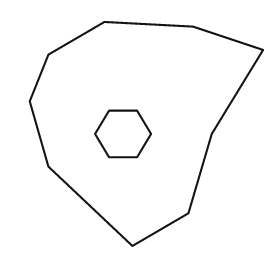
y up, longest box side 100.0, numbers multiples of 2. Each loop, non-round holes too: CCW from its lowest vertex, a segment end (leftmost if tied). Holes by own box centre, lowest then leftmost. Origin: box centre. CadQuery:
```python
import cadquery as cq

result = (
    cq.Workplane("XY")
    .moveTo(-6.0, -48.0)
    .lineTo(18.0, -34.0)
    .lineTo(28.0, 0.0)
    .lineTo(50.0, 36.0)
    .lineTo(20.0, 46.0)
    .lineTo(-18.0, 48.0)
    .lineTo(-42.0, 34.0)
    .lineTo(-50.0, 14.0)
    .lineTo(-42.0, -14.0)
    .close()
    .moveTo(-16.0, -10.0)
    .lineTo(-4.0, -10.0)
    .lineTo(2.0, 0.0)
    .lineTo(-4.0, 10.0)
    .lineTo(-16.0, 10.0)
    .lineTo(-22.0, 0.0)
    .close()
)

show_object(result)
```